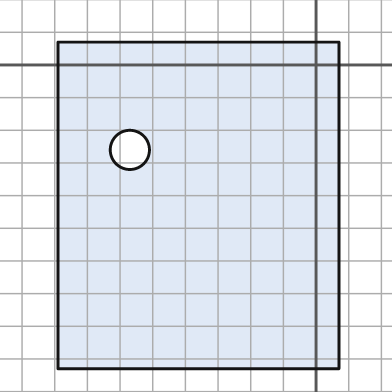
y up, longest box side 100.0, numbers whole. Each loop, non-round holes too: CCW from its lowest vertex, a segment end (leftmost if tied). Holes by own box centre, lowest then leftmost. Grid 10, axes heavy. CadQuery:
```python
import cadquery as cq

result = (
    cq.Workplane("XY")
    .moveTo(-79.0, -93.0)
    .lineTo(7.0, -93.0)
    .lineTo(7.0, 7.0)
    .lineTo(-79.0, 7.0)
    .close()
    .moveTo(-57.0, -26.0)
    .circle(6.0)
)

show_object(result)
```